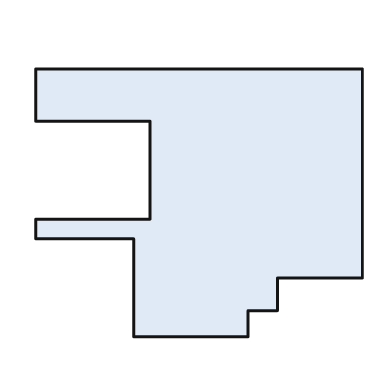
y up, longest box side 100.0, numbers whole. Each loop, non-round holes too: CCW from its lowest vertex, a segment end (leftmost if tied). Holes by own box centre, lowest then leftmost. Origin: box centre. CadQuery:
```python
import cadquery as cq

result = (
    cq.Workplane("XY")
    .moveTo(-20.0, -41.0)
    .lineTo(15.0, -41.0)
    .lineTo(15.0, -33.0)
    .lineTo(24.0, -33.0)
    .lineTo(24.0, -23.0)
    .lineTo(50.0, -23.0)
    .lineTo(50.0, 41.0)
    .lineTo(-50.0, 41.0)
    .lineTo(-50.0, 25.0)
    .lineTo(-15.0, 25.0)
    .lineTo(-15.0, -5.0)
    .lineTo(-50.0, -5.0)
    .lineTo(-50.0, -11.0)
    .lineTo(-20.0, -11.0)
    .close()
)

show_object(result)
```